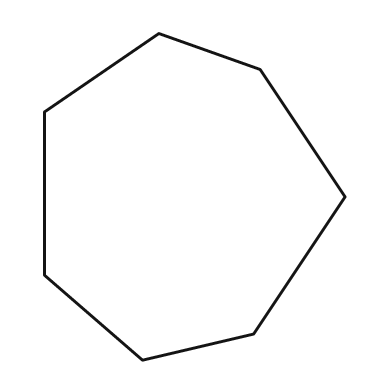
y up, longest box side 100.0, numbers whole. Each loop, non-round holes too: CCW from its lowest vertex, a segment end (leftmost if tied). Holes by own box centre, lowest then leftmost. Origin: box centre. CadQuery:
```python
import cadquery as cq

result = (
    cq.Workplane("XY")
    .moveTo(-16.0, -50.0)
    .lineTo(18.0, -42.0)
    .lineTo(46.0, 0.0)
    .lineTo(20.0, 39.0)
    .lineTo(-11.0, 50.0)
    .lineTo(-46.0, 26.0)
    .lineTo(-46.0, -24.0)
    .close()
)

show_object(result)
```